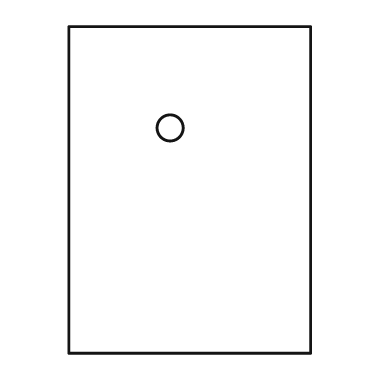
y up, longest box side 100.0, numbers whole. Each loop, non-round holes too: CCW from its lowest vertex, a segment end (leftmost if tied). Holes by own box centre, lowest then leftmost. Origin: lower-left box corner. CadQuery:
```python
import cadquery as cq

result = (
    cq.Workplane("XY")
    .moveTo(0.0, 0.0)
    .lineTo(74.0, 0.0)
    .lineTo(74.0, 100.0)
    .lineTo(0.0, 100.0)
    .close()
    .moveTo(31.0, 69.0)
    .circle(4.0)
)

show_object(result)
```